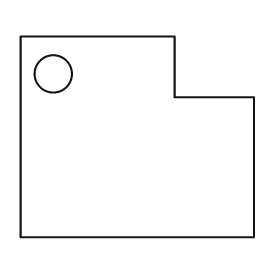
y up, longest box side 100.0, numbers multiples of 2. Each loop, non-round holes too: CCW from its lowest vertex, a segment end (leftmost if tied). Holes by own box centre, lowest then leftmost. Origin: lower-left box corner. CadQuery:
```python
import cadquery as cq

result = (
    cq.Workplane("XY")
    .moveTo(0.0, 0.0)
    .lineTo(100.0, 0.0)
    .lineTo(100.0, 60.0)
    .lineTo(66.0, 60.0)
    .lineTo(66.0, 86.0)
    .lineTo(0.0, 86.0)
    .close()
    .moveTo(14.0, 70.0)
    .circle(8.0)
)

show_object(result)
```